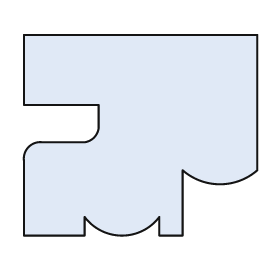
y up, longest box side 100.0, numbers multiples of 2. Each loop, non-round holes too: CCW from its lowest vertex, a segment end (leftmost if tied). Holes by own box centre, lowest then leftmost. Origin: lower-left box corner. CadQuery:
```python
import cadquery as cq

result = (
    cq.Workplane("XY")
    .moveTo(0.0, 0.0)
    .lineTo(26.0, 0.0)
    .lineTo(26.0, 8.0)
    .threePointArc((42.0, 0.0), (58.0, 8.0))
    .lineTo(58.0, 0.0)
    .lineTo(68.0, 0.0)
    .lineTo(68.0, 28.0)
    .threePointArc((84.0, 22.0), (100.0, 28.0))
    .lineTo(100.0, 86.0)
    .lineTo(0.0, 86.0)
    .lineTo(0.0, 56.0)
    .lineTo(32.0, 56.0)
    .lineTo(32.0, 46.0)
    .threePointArc((30.0, 42.0), (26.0, 40.0))
    .lineTo(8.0, 40.0)
    .threePointArc((2.0, 38.0), (0.0, 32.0))
    .close()
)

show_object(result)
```